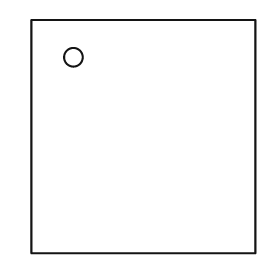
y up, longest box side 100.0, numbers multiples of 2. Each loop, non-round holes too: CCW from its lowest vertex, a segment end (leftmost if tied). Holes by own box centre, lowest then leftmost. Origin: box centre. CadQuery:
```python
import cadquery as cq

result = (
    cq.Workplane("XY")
    .moveTo(-48.0, -50.0)
    .lineTo(48.0, -50.0)
    .lineTo(48.0, 50.0)
    .lineTo(-48.0, 50.0)
    .close()
    .moveTo(-30.0, 34.0)
    .circle(4.0)
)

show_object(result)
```